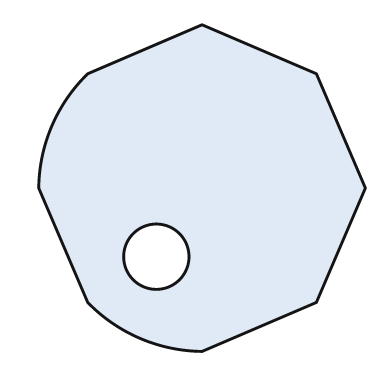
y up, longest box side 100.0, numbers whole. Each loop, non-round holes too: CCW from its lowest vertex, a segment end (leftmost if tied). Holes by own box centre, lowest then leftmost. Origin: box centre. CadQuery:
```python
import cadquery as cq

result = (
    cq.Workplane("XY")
    .moveTo(0.0, -50.0)
    .lineTo(35.0, -35.0)
    .lineTo(50.0, 0.0)
    .lineTo(35.0, 35.0)
    .lineTo(0.0, 50.0)
    .lineTo(-35.0, 35.0)
    .threePointArc((-46.0, 19.0), (-50.0, 0.0))
    .lineTo(-35.0, -35.0)
    .threePointArc((-19.0, -46.0), (0.0, -50.0))
    .close()
    .moveTo(-14.0, -21.0)
    .circle(10.0)
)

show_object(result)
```